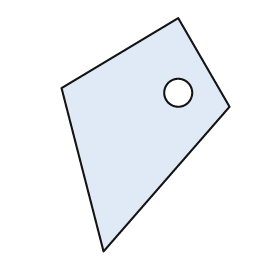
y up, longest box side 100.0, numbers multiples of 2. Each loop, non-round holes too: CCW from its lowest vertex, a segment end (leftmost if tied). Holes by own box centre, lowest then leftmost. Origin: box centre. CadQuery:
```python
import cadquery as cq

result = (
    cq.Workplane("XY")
    .moveTo(-18.0, -50.0)
    .lineTo(36.0, 12.0)
    .lineTo(14.0, 50.0)
    .lineTo(-36.0, 20.0)
    .close()
    .moveTo(14.0, 18.0)
    .circle(6.0)
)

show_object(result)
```